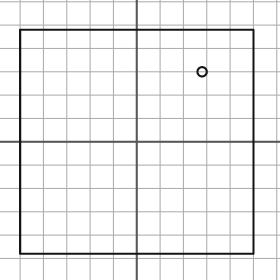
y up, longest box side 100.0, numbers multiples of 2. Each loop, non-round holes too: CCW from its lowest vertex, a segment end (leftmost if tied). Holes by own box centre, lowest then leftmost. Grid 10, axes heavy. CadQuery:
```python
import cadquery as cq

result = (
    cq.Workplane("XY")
    .moveTo(-50.0, -48.0)
    .lineTo(50.0, -48.0)
    .lineTo(50.0, 48.0)
    .lineTo(-50.0, 48.0)
    .close()
    .moveTo(28.0, 30.0)
    .circle(2.0)
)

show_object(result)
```